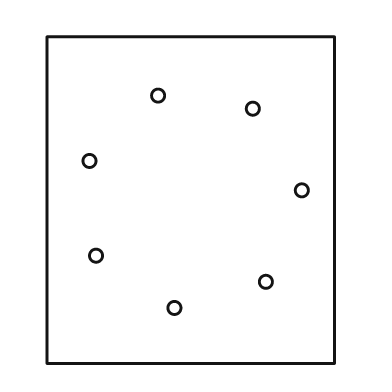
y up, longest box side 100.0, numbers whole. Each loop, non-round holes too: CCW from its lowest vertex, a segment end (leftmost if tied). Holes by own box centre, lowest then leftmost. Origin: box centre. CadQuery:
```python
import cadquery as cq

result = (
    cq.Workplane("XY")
    .moveTo(-44.0, -50.0)
    .lineTo(44.0, -50.0)
    .lineTo(44.0, 50.0)
    .lineTo(-44.0, 50.0)
    .close()
    .moveTo(-5.0, -33.0)
    .circle(2.0)
    .moveTo(23.0, -25.0)
    .circle(2.0)
    .moveTo(-29.0, -17.0)
    .circle(2.0)
    .moveTo(34.0, 3.0)
    .circle(2.0)
    .moveTo(-31.0, 12.0)
    .circle(2.0)
    .moveTo(19.0, 28.0)
    .circle(2.0)
    .moveTo(-10.0, 32.0)
    .circle(2.0)
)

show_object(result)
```